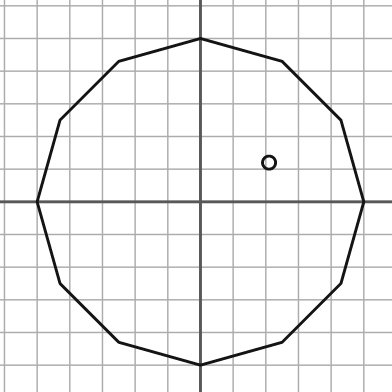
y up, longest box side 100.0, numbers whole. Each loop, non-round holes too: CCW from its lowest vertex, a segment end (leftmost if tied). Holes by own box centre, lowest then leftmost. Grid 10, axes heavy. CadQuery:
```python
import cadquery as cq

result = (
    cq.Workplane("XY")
    .moveTo(0.0, -50.0)
    .lineTo(25.0, -43.0)
    .lineTo(43.0, -25.0)
    .lineTo(50.0, 0.0)
    .lineTo(43.0, 25.0)
    .lineTo(25.0, 43.0)
    .lineTo(0.0, 50.0)
    .lineTo(-25.0, 43.0)
    .lineTo(-43.0, 25.0)
    .lineTo(-50.0, 0.0)
    .lineTo(-43.0, -25.0)
    .lineTo(-25.0, -43.0)
    .close()
    .moveTo(21.0, 12.0)
    .circle(2.0)
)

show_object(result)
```